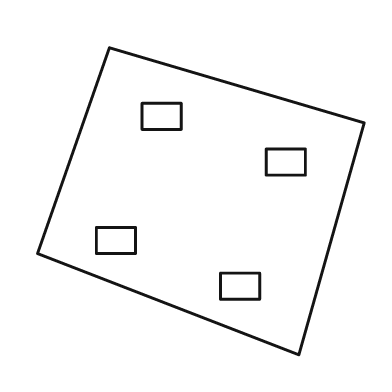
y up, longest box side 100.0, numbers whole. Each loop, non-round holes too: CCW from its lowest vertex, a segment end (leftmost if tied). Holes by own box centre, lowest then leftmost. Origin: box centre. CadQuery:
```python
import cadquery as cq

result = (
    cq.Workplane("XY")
    .moveTo(30.0, -47.0)
    .lineTo(50.0, 24.0)
    .lineTo(-28.0, 47.0)
    .lineTo(-50.0, -16.0)
    .close()
    .moveTo(6.0, -30.0)
    .lineTo(18.0, -30.0)
    .lineTo(18.0, -22.0)
    .lineTo(6.0, -22.0)
    .close()
    .moveTo(-32.0, -16.0)
    .lineTo(-20.0, -16.0)
    .lineTo(-20.0, -8.0)
    .lineTo(-32.0, -8.0)
    .close()
    .moveTo(20.0, 8.0)
    .lineTo(32.0, 8.0)
    .lineTo(32.0, 16.0)
    .lineTo(20.0, 16.0)
    .close()
    .moveTo(-18.0, 22.0)
    .lineTo(-6.0, 22.0)
    .lineTo(-6.0, 30.0)
    .lineTo(-18.0, 30.0)
    .close()
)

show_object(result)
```